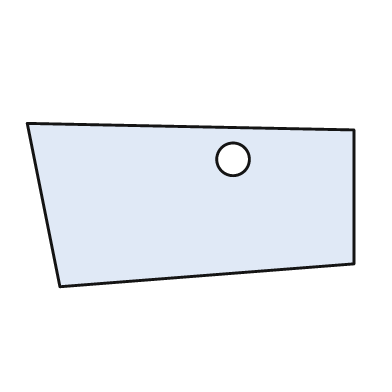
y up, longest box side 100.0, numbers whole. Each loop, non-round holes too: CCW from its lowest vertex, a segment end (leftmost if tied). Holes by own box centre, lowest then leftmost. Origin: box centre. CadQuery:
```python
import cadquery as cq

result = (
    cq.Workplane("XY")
    .moveTo(-40.0, -25.0)
    .lineTo(50.0, -18.0)
    .lineTo(50.0, 23.0)
    .lineTo(-50.0, 25.0)
    .close()
    .moveTo(13.0, 14.0)
    .circle(5.0)
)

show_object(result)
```